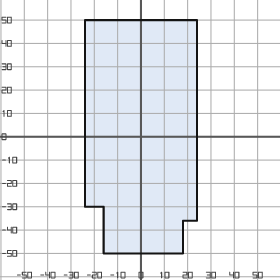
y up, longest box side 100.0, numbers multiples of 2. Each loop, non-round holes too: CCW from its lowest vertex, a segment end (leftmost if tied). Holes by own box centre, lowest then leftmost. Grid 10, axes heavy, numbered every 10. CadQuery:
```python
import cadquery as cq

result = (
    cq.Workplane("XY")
    .moveTo(-16.0, -50.0)
    .lineTo(18.0, -50.0)
    .lineTo(18.0, -36.0)
    .lineTo(24.0, -36.0)
    .lineTo(24.0, 50.0)
    .lineTo(-24.0, 50.0)
    .lineTo(-24.0, -30.0)
    .lineTo(-16.0, -30.0)
    .close()
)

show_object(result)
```